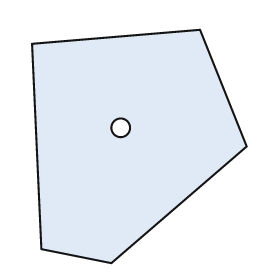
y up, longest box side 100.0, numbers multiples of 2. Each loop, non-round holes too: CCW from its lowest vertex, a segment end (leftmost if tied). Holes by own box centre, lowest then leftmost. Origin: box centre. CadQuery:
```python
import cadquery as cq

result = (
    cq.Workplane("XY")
    .moveTo(-12.0, -50.0)
    .lineTo(46.0, 0.0)
    .lineTo(26.0, 50.0)
    .lineTo(-46.0, 44.0)
    .lineTo(-42.0, -44.0)
    .close()
    .moveTo(-8.0, 8.0)
    .circle(4.0)
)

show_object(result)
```